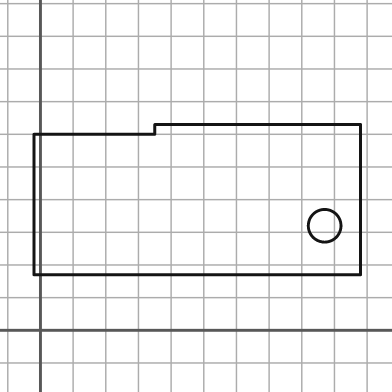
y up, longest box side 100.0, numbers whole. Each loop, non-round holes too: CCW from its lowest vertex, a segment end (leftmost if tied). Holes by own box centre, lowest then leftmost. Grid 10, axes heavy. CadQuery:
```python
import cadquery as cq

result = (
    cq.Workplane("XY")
    .moveTo(-2.0, 17.0)
    .lineTo(98.0, 17.0)
    .lineTo(98.0, 63.0)
    .lineTo(35.0, 63.0)
    .lineTo(35.0, 60.0)
    .lineTo(-2.0, 60.0)
    .close()
    .moveTo(87.0, 32.0)
    .circle(5.0)
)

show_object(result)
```